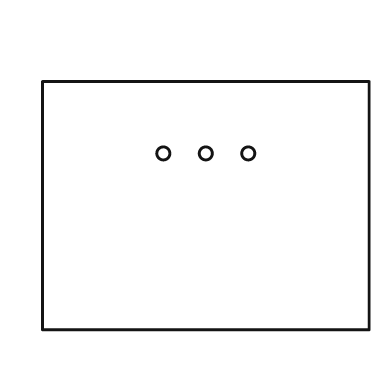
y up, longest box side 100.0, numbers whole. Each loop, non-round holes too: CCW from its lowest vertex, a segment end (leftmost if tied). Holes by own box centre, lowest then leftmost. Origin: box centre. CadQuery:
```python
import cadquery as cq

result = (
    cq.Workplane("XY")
    .moveTo(-50.0, -38.0)
    .lineTo(50.0, -38.0)
    .lineTo(50.0, 38.0)
    .lineTo(-50.0, 38.0)
    .close()
    .moveTo(-13.0, 16.0)
    .circle(2.0)
    .moveTo(0.0, 16.0)
    .circle(2.0)
    .moveTo(13.0, 16.0)
    .circle(2.0)
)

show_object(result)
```